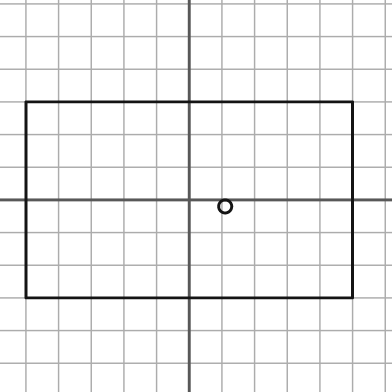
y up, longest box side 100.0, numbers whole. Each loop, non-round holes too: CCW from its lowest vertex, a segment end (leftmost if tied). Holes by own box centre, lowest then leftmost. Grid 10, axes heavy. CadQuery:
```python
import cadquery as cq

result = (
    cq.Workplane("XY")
    .moveTo(-50.0, -30.0)
    .lineTo(50.0, -30.0)
    .lineTo(50.0, 30.0)
    .lineTo(-50.0, 30.0)
    .close()
    .moveTo(11.0, -2.0)
    .circle(2.0)
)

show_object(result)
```